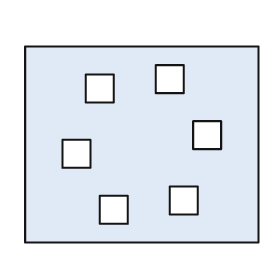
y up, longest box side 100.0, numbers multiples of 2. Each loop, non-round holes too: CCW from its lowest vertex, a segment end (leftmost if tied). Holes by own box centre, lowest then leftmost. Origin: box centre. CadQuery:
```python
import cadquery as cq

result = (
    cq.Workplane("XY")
    .moveTo(-50.0, -42.0)
    .lineTo(50.0, -42.0)
    .lineTo(50.0, 42.0)
    .lineTo(-50.0, 42.0)
    .close()
    .moveTo(-18.0, -34.0)
    .lineTo(-6.0, -34.0)
    .lineTo(-6.0, -22.0)
    .lineTo(-18.0, -22.0)
    .close()
    .moveTo(12.0, -30.0)
    .lineTo(24.0, -30.0)
    .lineTo(24.0, -18.0)
    .lineTo(12.0, -18.0)
    .close()
    .moveTo(-34.0, -10.0)
    .lineTo(-22.0, -10.0)
    .lineTo(-22.0, 2.0)
    .lineTo(-34.0, 2.0)
    .close()
    .moveTo(22.0, -2.0)
    .lineTo(34.0, -2.0)
    .lineTo(34.0, 10.0)
    .lineTo(22.0, 10.0)
    .close()
    .moveTo(-24.0, 18.0)
    .lineTo(-12.0, 18.0)
    .lineTo(-12.0, 30.0)
    .lineTo(-24.0, 30.0)
    .close()
    .moveTo(6.0, 22.0)
    .lineTo(18.0, 22.0)
    .lineTo(18.0, 34.0)
    .lineTo(6.0, 34.0)
    .close()
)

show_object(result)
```